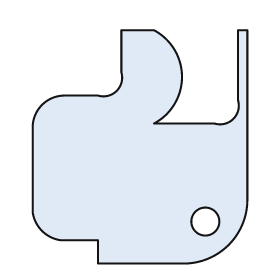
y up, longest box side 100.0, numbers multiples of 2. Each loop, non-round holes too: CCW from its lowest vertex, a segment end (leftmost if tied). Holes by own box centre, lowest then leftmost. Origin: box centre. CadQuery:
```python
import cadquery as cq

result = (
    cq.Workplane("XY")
    .moveTo(-18.0, -50.0)
    .lineTo(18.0, -50.0)
    .threePointArc((38.0, -42.0), (46.0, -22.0))
    .lineTo(46.0, 50.0)
    .lineTo(42.0, 50.0)
    .lineTo(42.0, 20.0)
    .threePointArc((40.0, 12.0), (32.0, 10.0))
    .lineTo(6.0, 10.0)
    .threePointArc((18.0, 30.0), (6.0, 50.0))
    .lineTo(-8.0, 50.0)
    .lineTo(-8.0, 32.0)
    .threePointArc((-10.0, 24.0), (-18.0, 22.0))
    .lineTo(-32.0, 22.0)
    .threePointArc((-42.0, 18.0), (-46.0, 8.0))
    .lineTo(-46.0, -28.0)
    .threePointArc((-42.0, -36.0), (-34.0, -40.0))
    .lineTo(-18.0, -40.0)
    .close()
    .moveTo(28.0, -32.0)
    .circle(6.0)
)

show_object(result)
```